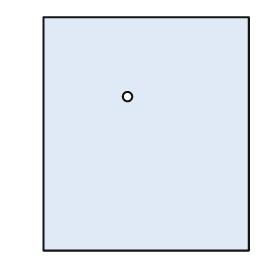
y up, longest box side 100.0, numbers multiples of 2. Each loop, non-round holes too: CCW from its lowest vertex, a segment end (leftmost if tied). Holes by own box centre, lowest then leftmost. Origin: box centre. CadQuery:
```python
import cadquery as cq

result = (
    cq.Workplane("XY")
    .moveTo(-44.0, -50.0)
    .lineTo(44.0, -50.0)
    .lineTo(44.0, 50.0)
    .lineTo(-44.0, 50.0)
    .close()
    .moveTo(-8.0, 16.0)
    .circle(2.0)
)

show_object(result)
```